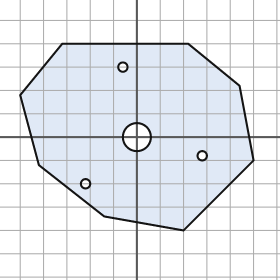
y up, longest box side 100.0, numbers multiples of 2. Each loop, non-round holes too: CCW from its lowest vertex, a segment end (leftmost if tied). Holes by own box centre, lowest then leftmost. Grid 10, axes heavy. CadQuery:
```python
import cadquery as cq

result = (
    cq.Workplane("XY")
    .moveTo(20.0, -40.0)
    .lineTo(50.0, -10.0)
    .lineTo(44.0, 22.0)
    .lineTo(22.0, 40.0)
    .lineTo(-32.0, 40.0)
    .lineTo(-50.0, 18.0)
    .lineTo(-42.0, -12.0)
    .lineTo(-14.0, -34.0)
    .close()
    .moveTo(-22.0, -20.0)
    .circle(2.0)
    .moveTo(28.0, -8.0)
    .circle(2.0)
    .moveTo(0.0, 0.0)
    .circle(6.0)
    .moveTo(-6.0, 30.0)
    .circle(2.0)
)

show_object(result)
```